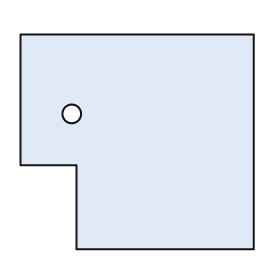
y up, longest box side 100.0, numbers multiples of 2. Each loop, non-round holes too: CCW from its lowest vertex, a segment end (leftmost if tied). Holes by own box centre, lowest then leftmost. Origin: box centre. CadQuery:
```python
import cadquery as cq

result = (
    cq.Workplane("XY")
    .moveTo(-26.0, -46.0)
    .lineTo(50.0, -46.0)
    .lineTo(50.0, 46.0)
    .lineTo(-50.0, 46.0)
    .lineTo(-50.0, -10.0)
    .lineTo(-26.0, -10.0)
    .close()
    .moveTo(-28.0, 12.0)
    .circle(4.0)
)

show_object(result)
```